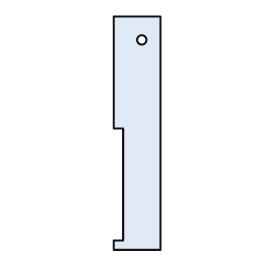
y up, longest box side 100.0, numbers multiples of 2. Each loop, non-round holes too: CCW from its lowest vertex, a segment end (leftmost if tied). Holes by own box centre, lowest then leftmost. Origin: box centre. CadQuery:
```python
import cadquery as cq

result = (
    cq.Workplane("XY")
    .moveTo(-10.0, -50.0)
    .lineTo(10.0, -50.0)
    .lineTo(10.0, 50.0)
    .lineTo(-10.0, 50.0)
    .lineTo(-10.0, 2.0)
    .lineTo(-6.0, 2.0)
    .lineTo(-6.0, -46.0)
    .lineTo(-10.0, -46.0)
    .close()
    .moveTo(2.0, 40.0)
    .circle(2.0)
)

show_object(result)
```